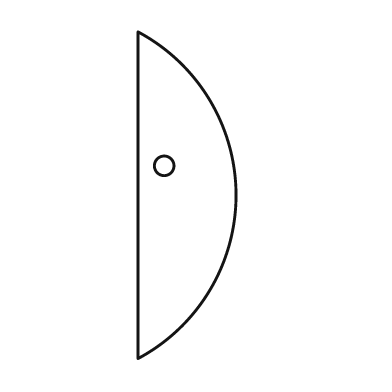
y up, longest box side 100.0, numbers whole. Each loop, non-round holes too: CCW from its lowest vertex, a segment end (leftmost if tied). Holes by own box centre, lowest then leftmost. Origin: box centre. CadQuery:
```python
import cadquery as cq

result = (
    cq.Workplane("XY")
    .moveTo(-15.0, -50.0)
    .threePointArc((15.0, 0.0), (-15.0, 50.0))
    .close()
    .moveTo(-7.0, 9.0)
    .circle(3.0)
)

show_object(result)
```